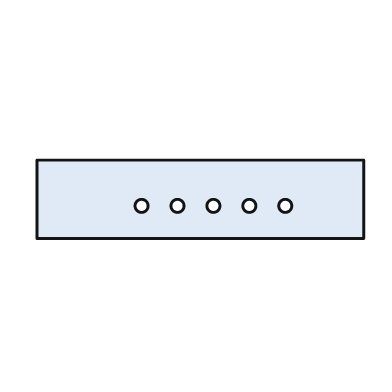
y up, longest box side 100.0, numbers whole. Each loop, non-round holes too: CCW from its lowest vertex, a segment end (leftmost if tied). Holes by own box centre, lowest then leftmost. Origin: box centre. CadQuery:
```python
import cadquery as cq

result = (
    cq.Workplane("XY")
    .moveTo(-50.0, -12.0)
    .lineTo(50.0, -12.0)
    .lineTo(50.0, 12.0)
    .lineTo(-50.0, 12.0)
    .close()
    .moveTo(-18.0, -2.0)
    .circle(2.0)
    .moveTo(-7.0, -2.0)
    .circle(2.0)
    .moveTo(4.0, -2.0)
    .circle(2.0)
    .moveTo(15.0, -2.0)
    .circle(2.0)
    .moveTo(26.0, -2.0)
    .circle(2.0)
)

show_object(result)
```